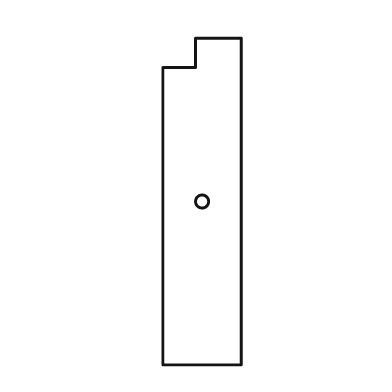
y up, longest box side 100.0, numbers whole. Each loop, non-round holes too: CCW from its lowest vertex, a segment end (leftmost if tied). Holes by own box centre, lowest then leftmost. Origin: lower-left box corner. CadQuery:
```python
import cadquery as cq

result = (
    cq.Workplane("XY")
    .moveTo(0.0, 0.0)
    .lineTo(24.0, 0.0)
    .lineTo(24.0, 100.0)
    .lineTo(10.0, 100.0)
    .lineTo(10.0, 91.0)
    .lineTo(0.0, 91.0)
    .close()
    .moveTo(12.0, 50.0)
    .circle(2.0)
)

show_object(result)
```